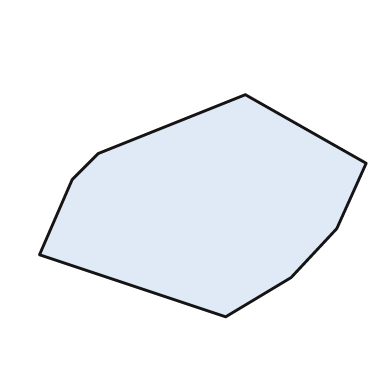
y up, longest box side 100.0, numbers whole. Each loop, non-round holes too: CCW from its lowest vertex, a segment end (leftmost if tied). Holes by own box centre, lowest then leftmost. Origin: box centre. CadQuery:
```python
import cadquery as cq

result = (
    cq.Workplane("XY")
    .moveTo(7.0, -34.0)
    .lineTo(27.0, -22.0)
    .lineTo(41.0, -7.0)
    .lineTo(50.0, 13.0)
    .lineTo(13.0, 34.0)
    .lineTo(-32.0, 16.0)
    .lineTo(-40.0, 8.0)
    .lineTo(-50.0, -15.0)
    .close()
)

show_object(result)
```